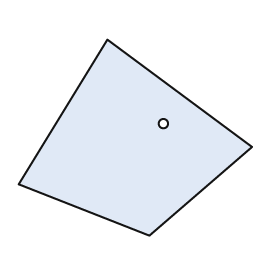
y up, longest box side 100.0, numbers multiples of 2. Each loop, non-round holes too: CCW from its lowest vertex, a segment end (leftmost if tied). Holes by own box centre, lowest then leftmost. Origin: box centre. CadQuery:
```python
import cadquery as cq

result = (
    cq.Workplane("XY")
    .moveTo(6.0, -42.0)
    .lineTo(50.0, -4.0)
    .lineTo(-12.0, 42.0)
    .lineTo(-50.0, -20.0)
    .close()
    .moveTo(12.0, 6.0)
    .circle(2.0)
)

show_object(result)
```